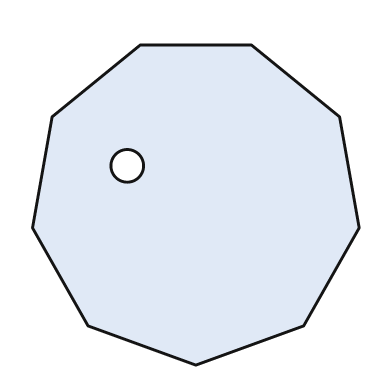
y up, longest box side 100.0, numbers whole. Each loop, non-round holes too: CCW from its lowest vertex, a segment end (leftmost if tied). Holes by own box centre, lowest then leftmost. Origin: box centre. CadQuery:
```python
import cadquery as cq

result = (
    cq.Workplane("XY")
    .moveTo(0.0, -49.0)
    .lineTo(33.0, -37.0)
    .lineTo(50.0, -7.0)
    .lineTo(44.0, 27.0)
    .lineTo(17.0, 49.0)
    .lineTo(-17.0, 49.0)
    .lineTo(-44.0, 27.0)
    .lineTo(-50.0, -7.0)
    .lineTo(-33.0, -37.0)
    .close()
    .moveTo(-21.0, 12.0)
    .circle(5.0)
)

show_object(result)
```